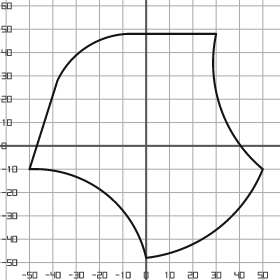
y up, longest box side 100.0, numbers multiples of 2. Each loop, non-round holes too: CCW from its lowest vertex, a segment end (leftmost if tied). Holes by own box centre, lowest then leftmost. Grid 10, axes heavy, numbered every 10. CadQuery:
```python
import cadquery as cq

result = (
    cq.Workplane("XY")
    .moveTo(0.0, -48.0)
    .threePointArc((30.0, -36.0), (50.0, -10.0))
    .threePointArc((32.0, 16.0), (30.0, 48.0))
    .lineTo(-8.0, 48.0)
    .threePointArc((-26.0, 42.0), (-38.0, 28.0))
    .lineTo(-50.0, -10.0)
    .threePointArc((-18.0, -20.0), (0.0, -48.0))
    .close()
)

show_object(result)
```